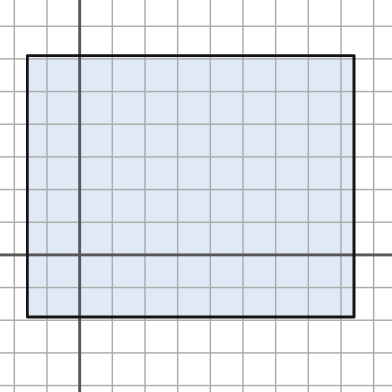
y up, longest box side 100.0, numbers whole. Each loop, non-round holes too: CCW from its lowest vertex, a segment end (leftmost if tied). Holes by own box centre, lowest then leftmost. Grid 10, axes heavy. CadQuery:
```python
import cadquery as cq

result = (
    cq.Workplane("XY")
    .moveTo(-16.0, -19.0)
    .lineTo(84.0, -19.0)
    .lineTo(84.0, 61.0)
    .lineTo(-16.0, 61.0)
    .close()
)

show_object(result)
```